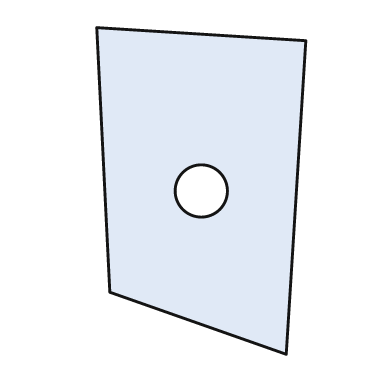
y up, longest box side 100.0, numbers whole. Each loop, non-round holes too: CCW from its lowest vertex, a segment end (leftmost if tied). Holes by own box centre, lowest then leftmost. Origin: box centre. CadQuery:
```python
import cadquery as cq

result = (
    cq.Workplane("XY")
    .moveTo(26.0, -50.0)
    .lineTo(32.0, 46.0)
    .lineTo(-32.0, 50.0)
    .lineTo(-28.0, -31.0)
    .close()
    .moveTo(0.0, 0.0)
    .circle(8.0)
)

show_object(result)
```